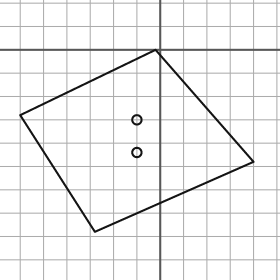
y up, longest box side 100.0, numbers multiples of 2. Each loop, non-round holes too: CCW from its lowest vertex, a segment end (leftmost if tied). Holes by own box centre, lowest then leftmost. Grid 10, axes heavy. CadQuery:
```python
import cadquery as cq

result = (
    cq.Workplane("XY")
    .moveTo(-28.0, -78.0)
    .lineTo(40.0, -48.0)
    .lineTo(-2.0, 0.0)
    .lineTo(-60.0, -28.0)
    .close()
    .moveTo(-10.0, -44.0)
    .circle(2.0)
    .moveTo(-10.0, -30.0)
    .circle(2.0)
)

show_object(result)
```